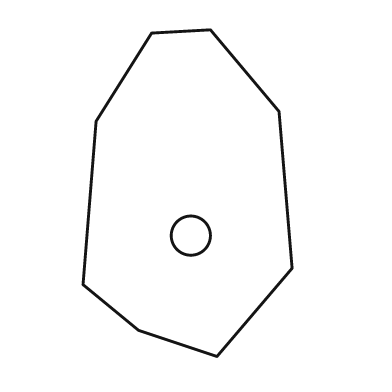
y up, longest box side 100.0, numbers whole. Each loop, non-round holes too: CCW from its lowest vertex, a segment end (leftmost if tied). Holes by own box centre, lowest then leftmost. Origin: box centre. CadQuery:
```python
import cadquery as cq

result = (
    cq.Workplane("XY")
    .moveTo(9.0, -50.0)
    .lineTo(32.0, -23.0)
    .lineTo(28.0, 25.0)
    .lineTo(7.0, 50.0)
    .lineTo(-11.0, 49.0)
    .lineTo(-28.0, 22.0)
    .lineTo(-32.0, -28.0)
    .lineTo(-15.0, -42.0)
    .close()
    .moveTo(1.0, -13.0)
    .circle(6.0)
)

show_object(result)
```